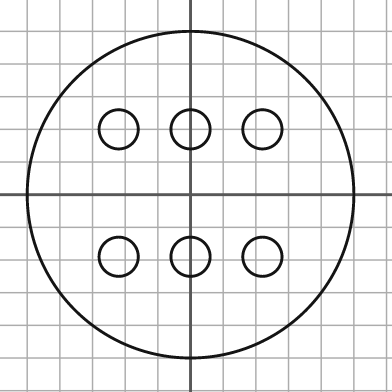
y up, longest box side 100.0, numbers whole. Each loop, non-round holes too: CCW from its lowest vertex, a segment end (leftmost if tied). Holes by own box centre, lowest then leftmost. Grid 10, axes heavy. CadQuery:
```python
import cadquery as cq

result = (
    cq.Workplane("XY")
    .moveTo(0.0, 0.0)
    .circle(50.0)
    .moveTo(-22.0, -19.0)
    .circle(6.0)
    .moveTo(0.0, -19.0)
    .circle(6.0)
    .moveTo(22.0, -19.0)
    .circle(6.0)
    .moveTo(-22.0, 20.0)
    .circle(6.0)
    .moveTo(0.0, 20.0)
    .circle(6.0)
    .moveTo(22.0, 20.0)
    .circle(6.0)
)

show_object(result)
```